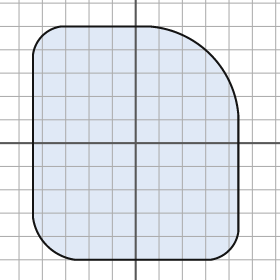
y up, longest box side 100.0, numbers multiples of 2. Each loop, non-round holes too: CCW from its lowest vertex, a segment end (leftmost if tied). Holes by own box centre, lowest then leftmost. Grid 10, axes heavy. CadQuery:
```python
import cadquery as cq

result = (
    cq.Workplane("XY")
    .moveTo(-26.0, -50.0)
    .lineTo(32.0, -50.0)
    .threePointArc((40.0, -46.0), (44.0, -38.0))
    .lineTo(44.0, 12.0)
    .threePointArc((32.0, 38.0), (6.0, 50.0))
    .lineTo(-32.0, 50.0)
    .threePointArc((-40.0, 46.0), (-44.0, 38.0))
    .lineTo(-44.0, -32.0)
    .threePointArc((-38.0, -44.0), (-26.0, -50.0))
    .close()
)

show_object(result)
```